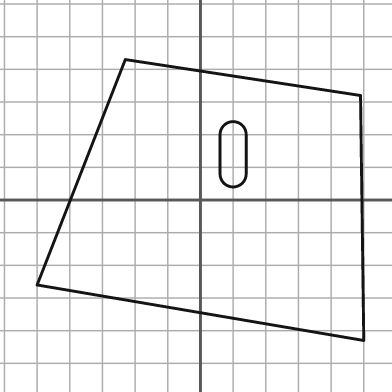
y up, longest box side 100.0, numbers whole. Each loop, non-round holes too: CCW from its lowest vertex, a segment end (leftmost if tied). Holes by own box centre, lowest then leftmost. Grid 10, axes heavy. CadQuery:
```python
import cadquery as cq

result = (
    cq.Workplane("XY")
    .moveTo(50.0, -43.0)
    .lineTo(49.0, 32.0)
    .lineTo(-23.0, 43.0)
    .lineTo(-50.0, -26.0)
    .close()
    .moveTo(6.0, 8.0)
    .threePointArc((10.0, 4.0), (14.0, 8.0))
    .lineTo(14.0, 20.0)
    .threePointArc((10.0, 24.0), (6.0, 20.0))
    .close()
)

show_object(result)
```